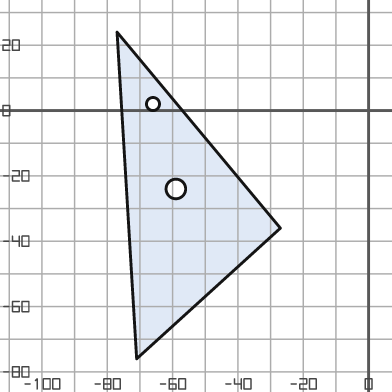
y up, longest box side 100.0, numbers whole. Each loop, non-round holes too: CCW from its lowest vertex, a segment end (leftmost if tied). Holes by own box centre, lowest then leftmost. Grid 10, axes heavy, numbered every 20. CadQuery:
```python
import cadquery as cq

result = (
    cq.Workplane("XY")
    .moveTo(-71.0, -76.0)
    .lineTo(-27.0, -36.0)
    .lineTo(-77.0, 24.0)
    .close()
    .moveTo(-59.0, -24.0)
    .circle(3.0)
    .moveTo(-66.0, 2.0)
    .circle(2.0)
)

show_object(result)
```